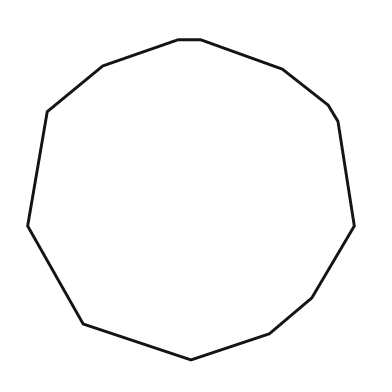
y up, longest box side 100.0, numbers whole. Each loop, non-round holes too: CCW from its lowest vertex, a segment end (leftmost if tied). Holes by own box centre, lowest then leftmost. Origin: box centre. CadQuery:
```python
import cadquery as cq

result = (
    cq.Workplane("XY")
    .moveTo(0.0, -49.0)
    .lineTo(24.0, -41.0)
    .lineTo(37.0, -30.0)
    .lineTo(50.0, -8.0)
    .lineTo(45.0, 24.0)
    .lineTo(42.0, 29.0)
    .lineTo(28.0, 40.0)
    .lineTo(3.0, 49.0)
    .lineTo(-4.0, 49.0)
    .lineTo(-27.0, 41.0)
    .lineTo(-44.0, 27.0)
    .lineTo(-50.0, -8.0)
    .lineTo(-33.0, -38.0)
    .close()
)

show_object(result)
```